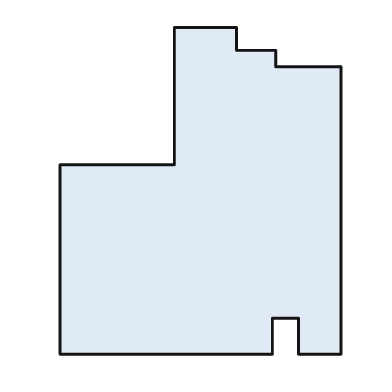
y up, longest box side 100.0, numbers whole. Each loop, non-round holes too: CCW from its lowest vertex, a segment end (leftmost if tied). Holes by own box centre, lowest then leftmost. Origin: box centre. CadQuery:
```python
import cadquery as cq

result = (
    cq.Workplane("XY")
    .moveTo(-43.0, -50.0)
    .lineTo(22.0, -50.0)
    .lineTo(22.0, -39.0)
    .lineTo(30.0, -39.0)
    .lineTo(30.0, -50.0)
    .lineTo(43.0, -50.0)
    .lineTo(43.0, 38.0)
    .lineTo(23.0, 38.0)
    .lineTo(23.0, 43.0)
    .lineTo(11.0, 43.0)
    .lineTo(11.0, 50.0)
    .lineTo(-8.0, 50.0)
    .lineTo(-8.0, 8.0)
    .lineTo(-43.0, 8.0)
    .close()
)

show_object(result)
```